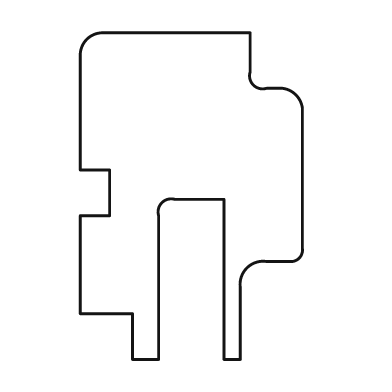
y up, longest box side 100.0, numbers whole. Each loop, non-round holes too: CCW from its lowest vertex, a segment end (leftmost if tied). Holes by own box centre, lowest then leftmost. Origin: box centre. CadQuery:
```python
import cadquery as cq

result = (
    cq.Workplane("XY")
    .moveTo(-18.0, -50.0)
    .lineTo(-10.0, -50.0)
    .lineTo(-10.0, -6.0)
    .threePointArc((-9.0, -2.0), (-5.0, -1.0))
    .lineTo(10.0, -1.0)
    .lineTo(10.0, -50.0)
    .lineTo(15.0, -50.0)
    .lineTo(15.0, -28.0)
    .threePointArc((17.0, -22.0), (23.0, -20.0))
    .lineTo(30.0, -20.0)
    .threePointArc((33.0, -19.0), (34.0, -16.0))
    .lineTo(34.0, 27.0)
    .threePointArc((32.0, 31.0), (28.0, 33.0))
    .lineTo(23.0, 33.0)
    .threePointArc((19.0, 34.0), (18.0, 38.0))
    .lineTo(18.0, 50.0)
    .lineTo(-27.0, 50.0)
    .threePointArc((-32.0, 48.0), (-34.0, 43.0))
    .lineTo(-34.0, 8.0)
    .lineTo(-25.0, 8.0)
    .lineTo(-25.0, -6.0)
    .lineTo(-34.0, -6.0)
    .lineTo(-34.0, -36.0)
    .lineTo(-18.0, -36.0)
    .close()
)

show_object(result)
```